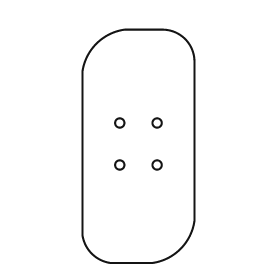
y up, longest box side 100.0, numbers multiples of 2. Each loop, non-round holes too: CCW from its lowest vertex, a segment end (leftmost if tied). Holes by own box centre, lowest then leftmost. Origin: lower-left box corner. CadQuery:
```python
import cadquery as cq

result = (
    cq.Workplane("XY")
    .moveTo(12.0, 0.0)
    .lineTo(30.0, 0.0)
    .threePointArc((42.0, 6.0), (48.0, 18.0))
    .lineTo(48.0, 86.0)
    .threePointArc((44.0, 96.0), (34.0, 100.0))
    .lineTo(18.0, 100.0)
    .threePointArc((6.0, 94.0), (0.0, 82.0))
    .lineTo(0.0, 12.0)
    .threePointArc((4.0, 4.0), (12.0, 0.0))
    .close()
    .moveTo(16.0, 42.0)
    .circle(2.0)
    .moveTo(32.0, 42.0)
    .circle(2.0)
    .moveTo(16.0, 60.0)
    .circle(2.0)
    .moveTo(32.0, 60.0)
    .circle(2.0)
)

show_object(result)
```